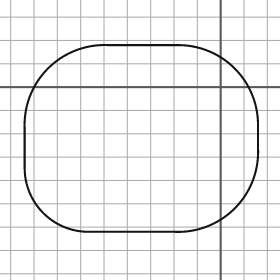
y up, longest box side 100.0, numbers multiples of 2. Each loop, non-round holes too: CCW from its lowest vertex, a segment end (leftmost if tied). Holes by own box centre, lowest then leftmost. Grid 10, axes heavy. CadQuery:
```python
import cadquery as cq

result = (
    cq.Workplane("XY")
    .moveTo(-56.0, -62.0)
    .lineTo(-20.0, -62.0)
    .threePointArc((6.0, -52.0), (16.0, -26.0))
    .lineTo(16.0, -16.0)
    .threePointArc((6.0, 8.0), (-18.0, 18.0))
    .lineTo(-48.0, 18.0)
    .threePointArc((-74.0, 8.0), (-84.0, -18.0))
    .lineTo(-84.0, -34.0)
    .threePointArc((-76.0, -54.0), (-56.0, -62.0))
    .close()
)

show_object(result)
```